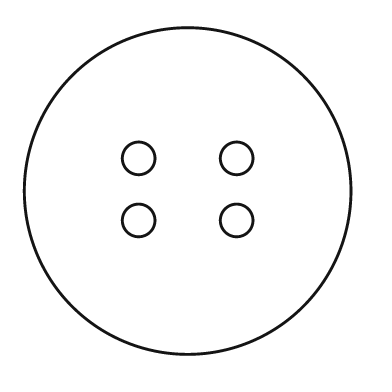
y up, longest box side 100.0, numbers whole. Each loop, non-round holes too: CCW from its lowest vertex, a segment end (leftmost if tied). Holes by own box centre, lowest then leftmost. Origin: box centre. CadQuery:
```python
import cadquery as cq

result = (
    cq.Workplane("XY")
    .moveTo(0.0, 0.0)
    .circle(50.0)
    .moveTo(-15.0, -9.0)
    .circle(5.0)
    .moveTo(15.0, -9.0)
    .circle(5.0)
    .moveTo(-15.0, 10.0)
    .circle(5.0)
    .moveTo(15.0, 10.0)
    .circle(5.0)
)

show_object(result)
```